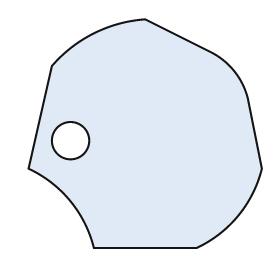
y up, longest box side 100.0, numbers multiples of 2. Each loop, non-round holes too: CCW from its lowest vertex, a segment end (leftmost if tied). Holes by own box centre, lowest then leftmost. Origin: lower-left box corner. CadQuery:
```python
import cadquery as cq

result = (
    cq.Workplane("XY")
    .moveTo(28.0, 0.0)
    .lineTo(72.0, 0.0)
    .threePointArc((90.0, 14.0), (100.0, 34.0))
    .lineTo(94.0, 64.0)
    .threePointArc((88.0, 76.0), (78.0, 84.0))
    .lineTo(50.0, 98.0)
    .threePointArc((28.0, 92.0), (10.0, 78.0))
    .lineTo(0.0, 34.0)
    .threePointArc((18.0, 20.0), (28.0, 0.0))
    .close()
    .moveTo(18.0, 46.0)
    .circle(8.0)
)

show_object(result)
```